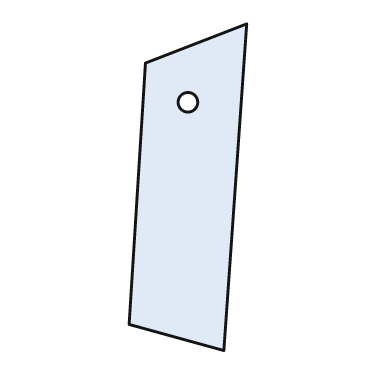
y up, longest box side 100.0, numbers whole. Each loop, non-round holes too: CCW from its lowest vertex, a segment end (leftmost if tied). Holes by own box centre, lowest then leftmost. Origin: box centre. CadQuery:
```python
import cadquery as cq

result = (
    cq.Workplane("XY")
    .moveTo(11.0, -50.0)
    .lineTo(18.0, 50.0)
    .lineTo(-13.0, 38.0)
    .lineTo(-18.0, -42.0)
    .close()
    .moveTo(0.0, 26.0)
    .circle(3.0)
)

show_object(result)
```